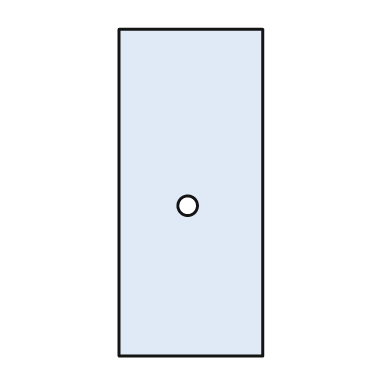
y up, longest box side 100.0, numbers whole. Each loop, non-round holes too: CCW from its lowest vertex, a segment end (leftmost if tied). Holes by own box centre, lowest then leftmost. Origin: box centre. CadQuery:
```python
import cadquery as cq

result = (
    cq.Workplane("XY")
    .moveTo(-22.0, -50.0)
    .lineTo(22.0, -50.0)
    .lineTo(22.0, 50.0)
    .lineTo(-22.0, 50.0)
    .close()
    .moveTo(-1.0, -4.0)
    .circle(3.0)
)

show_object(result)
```